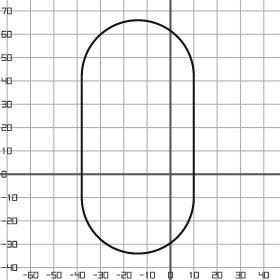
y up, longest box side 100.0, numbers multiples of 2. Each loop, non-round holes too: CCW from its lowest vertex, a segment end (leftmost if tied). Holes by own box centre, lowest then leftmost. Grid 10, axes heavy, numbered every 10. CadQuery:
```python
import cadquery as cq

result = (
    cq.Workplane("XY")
    .moveTo(-38.0, -10.0)
    .threePointArc((-14.0, -34.0), (10.0, -10.0))
    .lineTo(10.0, 42.0)
    .threePointArc((-14.0, 66.0), (-38.0, 42.0))
    .close()
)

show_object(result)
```